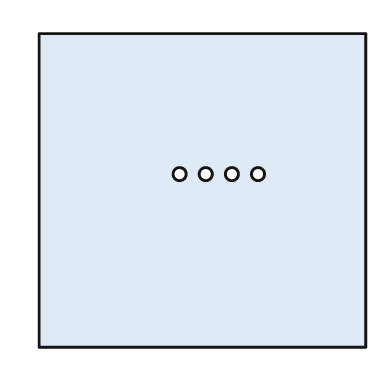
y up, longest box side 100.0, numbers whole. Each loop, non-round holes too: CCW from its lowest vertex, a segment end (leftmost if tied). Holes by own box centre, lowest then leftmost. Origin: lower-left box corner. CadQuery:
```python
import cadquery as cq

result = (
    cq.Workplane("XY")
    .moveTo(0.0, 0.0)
    .lineTo(100.0, 0.0)
    .lineTo(100.0, 96.0)
    .lineTo(0.0, 96.0)
    .close()
    .moveTo(43.0, 53.0)
    .circle(2.0)
    .moveTo(51.0, 53.0)
    .circle(2.0)
    .moveTo(59.0, 53.0)
    .circle(2.0)
    .moveTo(67.0, 53.0)
    .circle(2.0)
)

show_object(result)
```